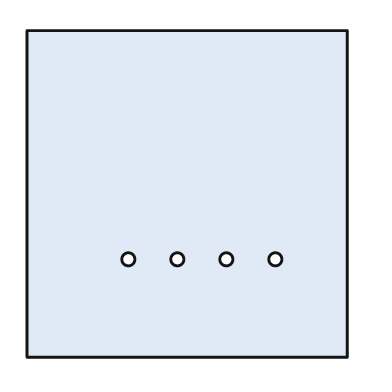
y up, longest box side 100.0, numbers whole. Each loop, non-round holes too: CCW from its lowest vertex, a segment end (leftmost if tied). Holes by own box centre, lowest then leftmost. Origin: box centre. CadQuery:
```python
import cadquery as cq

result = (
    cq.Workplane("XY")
    .moveTo(-49.0, -50.0)
    .lineTo(49.0, -50.0)
    .lineTo(49.0, 50.0)
    .lineTo(-49.0, 50.0)
    .close()
    .moveTo(-18.0, -20.0)
    .circle(2.0)
    .moveTo(-3.0, -20.0)
    .circle(2.0)
    .moveTo(12.0, -20.0)
    .circle(2.0)
    .moveTo(27.0, -20.0)
    .circle(2.0)
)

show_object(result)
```